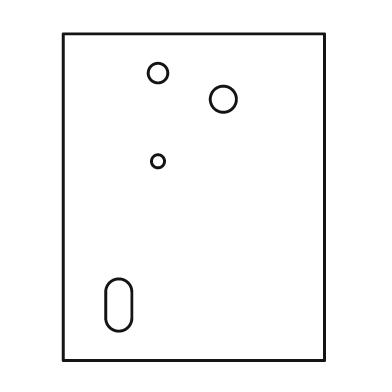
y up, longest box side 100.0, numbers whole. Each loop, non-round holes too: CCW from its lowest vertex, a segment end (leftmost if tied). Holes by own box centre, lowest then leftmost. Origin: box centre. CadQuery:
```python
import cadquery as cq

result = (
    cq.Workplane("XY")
    .moveTo(-40.0, -50.0)
    .lineTo(40.0, -50.0)
    .lineTo(40.0, 50.0)
    .lineTo(-40.0, 50.0)
    .close()
    .moveTo(-27.0, -37.0)
    .threePointArc((-23.0, -41.0), (-19.0, -37.0))
    .lineTo(-19.0, -29.0)
    .threePointArc((-23.0, -25.0), (-27.0, -29.0))
    .close()
    .moveTo(-11.0, 11.0)
    .circle(2.0)
    .moveTo(9.0, 30.0)
    .circle(4.0)
    .moveTo(-11.0, 38.0)
    .circle(3.0)
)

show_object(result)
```